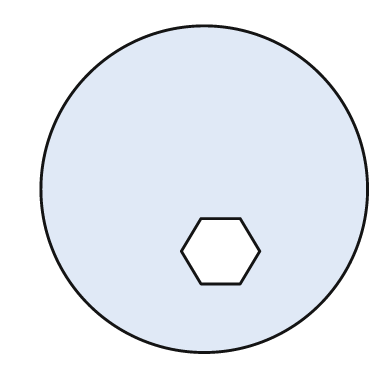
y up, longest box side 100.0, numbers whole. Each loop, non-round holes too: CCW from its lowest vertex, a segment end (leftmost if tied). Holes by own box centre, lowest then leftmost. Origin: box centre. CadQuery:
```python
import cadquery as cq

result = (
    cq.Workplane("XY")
    .moveTo(0.0, 0.0)
    .circle(50.0)
    .moveTo(-1.0, -29.0)
    .lineTo(11.0, -29.0)
    .lineTo(17.0, -19.0)
    .lineTo(11.0, -9.0)
    .lineTo(-1.0, -9.0)
    .lineTo(-7.0, -19.0)
    .close()
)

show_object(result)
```